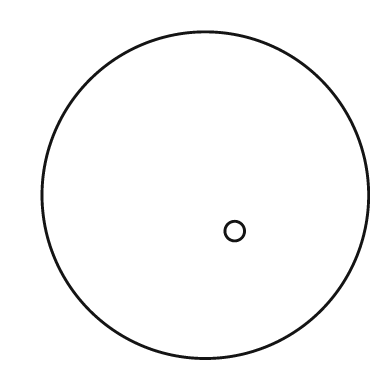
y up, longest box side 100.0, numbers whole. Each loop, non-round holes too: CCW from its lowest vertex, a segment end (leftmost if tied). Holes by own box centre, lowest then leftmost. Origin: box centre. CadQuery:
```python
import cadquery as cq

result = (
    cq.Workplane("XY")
    .moveTo(0.0, 0.0)
    .circle(50.0)
    .moveTo(9.0, -11.0)
    .circle(3.0)
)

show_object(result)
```